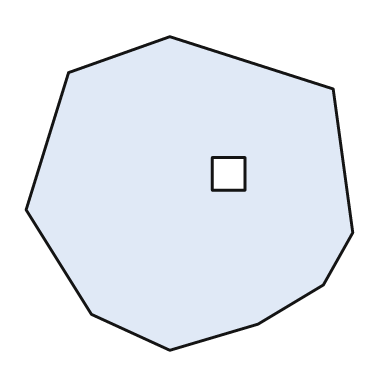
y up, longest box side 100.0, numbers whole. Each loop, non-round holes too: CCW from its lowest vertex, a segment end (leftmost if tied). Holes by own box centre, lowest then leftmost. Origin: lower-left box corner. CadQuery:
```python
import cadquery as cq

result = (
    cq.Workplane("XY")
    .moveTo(44.0, 0.0)
    .lineTo(71.0, 8.0)
    .lineTo(91.0, 20.0)
    .lineTo(100.0, 36.0)
    .lineTo(94.0, 80.0)
    .lineTo(44.0, 96.0)
    .lineTo(13.0, 85.0)
    .lineTo(0.0, 43.0)
    .lineTo(20.0, 11.0)
    .close()
    .moveTo(57.0, 49.0)
    .lineTo(67.0, 49.0)
    .lineTo(67.0, 59.0)
    .lineTo(57.0, 59.0)
    .close()
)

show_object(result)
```